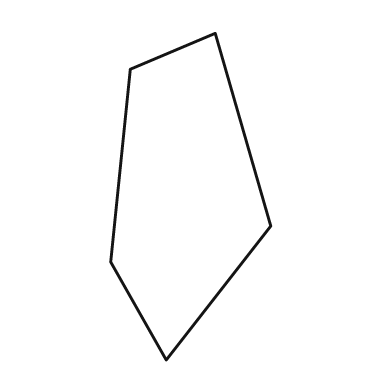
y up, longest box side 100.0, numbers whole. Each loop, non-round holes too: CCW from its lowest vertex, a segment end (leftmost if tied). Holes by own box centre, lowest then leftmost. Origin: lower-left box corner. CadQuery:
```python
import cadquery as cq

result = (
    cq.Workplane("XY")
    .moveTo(17.0, 0.0)
    .lineTo(49.0, 41.0)
    .lineTo(32.0, 100.0)
    .lineTo(6.0, 89.0)
    .lineTo(0.0, 30.0)
    .close()
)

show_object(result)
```